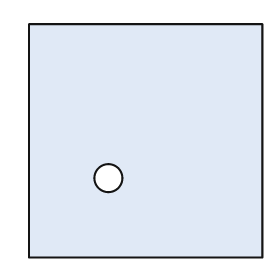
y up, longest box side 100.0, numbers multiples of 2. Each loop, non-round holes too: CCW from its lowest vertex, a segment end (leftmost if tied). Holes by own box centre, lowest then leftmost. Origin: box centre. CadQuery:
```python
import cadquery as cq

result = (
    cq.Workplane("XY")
    .moveTo(-50.0, -50.0)
    .lineTo(50.0, -50.0)
    .lineTo(50.0, 50.0)
    .lineTo(-50.0, 50.0)
    .close()
    .moveTo(-16.0, -16.0)
    .circle(6.0)
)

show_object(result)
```